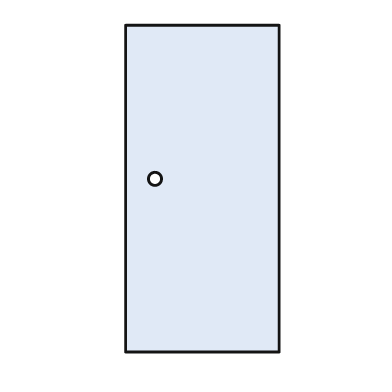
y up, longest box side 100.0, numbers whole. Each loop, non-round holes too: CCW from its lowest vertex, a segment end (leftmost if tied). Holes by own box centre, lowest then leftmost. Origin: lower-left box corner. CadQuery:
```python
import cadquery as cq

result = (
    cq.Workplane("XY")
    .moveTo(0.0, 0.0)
    .lineTo(47.0, 0.0)
    .lineTo(47.0, 100.0)
    .lineTo(0.0, 100.0)
    .close()
    .moveTo(9.0, 53.0)
    .circle(2.0)
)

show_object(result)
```